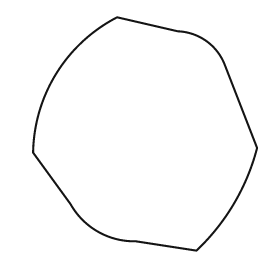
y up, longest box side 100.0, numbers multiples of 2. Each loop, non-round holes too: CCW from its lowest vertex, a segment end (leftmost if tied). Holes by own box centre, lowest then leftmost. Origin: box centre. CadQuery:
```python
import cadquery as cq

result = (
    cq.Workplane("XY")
    .moveTo(22.0, -50.0)
    .threePointArc((38.0, -30.0), (48.0, -6.0))
    .lineTo(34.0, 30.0)
    .threePointArc((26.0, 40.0), (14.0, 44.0))
    .lineTo(-12.0, 50.0)
    .threePointArc((-38.0, 26.0), (-48.0, -8.0))
    .lineTo(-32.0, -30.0)
    .threePointArc((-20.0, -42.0), (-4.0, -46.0))
    .close()
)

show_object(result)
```